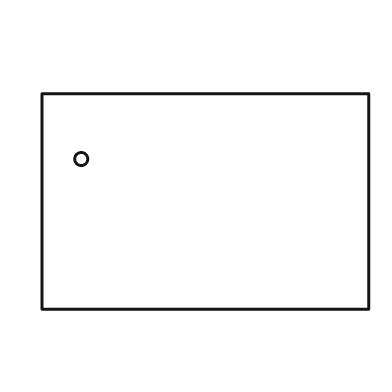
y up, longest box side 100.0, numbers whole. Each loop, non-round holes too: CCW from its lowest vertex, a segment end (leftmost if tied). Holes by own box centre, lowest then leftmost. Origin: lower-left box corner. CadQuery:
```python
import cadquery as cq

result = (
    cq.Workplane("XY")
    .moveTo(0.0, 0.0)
    .lineTo(100.0, 0.0)
    .lineTo(100.0, 66.0)
    .lineTo(0.0, 66.0)
    .close()
    .moveTo(12.0, 46.0)
    .circle(2.0)
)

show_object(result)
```